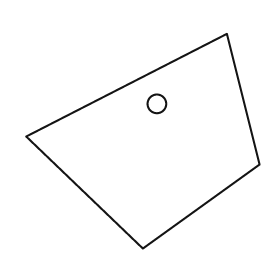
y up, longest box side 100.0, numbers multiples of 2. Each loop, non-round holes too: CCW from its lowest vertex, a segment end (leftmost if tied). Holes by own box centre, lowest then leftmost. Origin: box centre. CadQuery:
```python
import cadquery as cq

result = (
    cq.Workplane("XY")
    .moveTo(0.0, -46.0)
    .lineTo(50.0, -10.0)
    .lineTo(36.0, 46.0)
    .lineTo(-50.0, 2.0)
    .close()
    .moveTo(6.0, 16.0)
    .circle(4.0)
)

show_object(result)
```